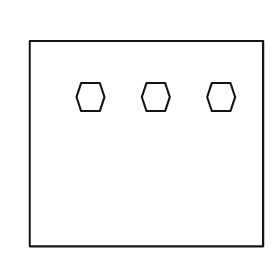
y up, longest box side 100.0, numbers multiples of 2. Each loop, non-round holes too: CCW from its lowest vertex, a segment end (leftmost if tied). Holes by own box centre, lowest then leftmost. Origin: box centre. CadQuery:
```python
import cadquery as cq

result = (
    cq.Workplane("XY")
    .moveTo(-50.0, -44.0)
    .lineTo(50.0, -44.0)
    .lineTo(50.0, 44.0)
    .lineTo(-50.0, 44.0)
    .close()
    .moveTo(-28.0, 14.0)
    .lineTo(-20.0, 14.0)
    .lineTo(-18.0, 20.0)
    .lineTo(-20.0, 26.0)
    .lineTo(-28.0, 26.0)
    .lineTo(-30.0, 20.0)
    .close()
    .moveTo(0.0, 14.0)
    .lineTo(8.0, 14.0)
    .lineTo(10.0, 20.0)
    .lineTo(8.0, 26.0)
    .lineTo(0.0, 26.0)
    .lineTo(-2.0, 20.0)
    .close()
    .moveTo(28.0, 14.0)
    .lineTo(36.0, 14.0)
    .lineTo(38.0, 20.0)
    .lineTo(36.0, 26.0)
    .lineTo(28.0, 26.0)
    .lineTo(26.0, 20.0)
    .close()
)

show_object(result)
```